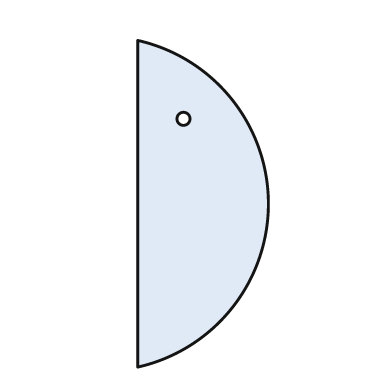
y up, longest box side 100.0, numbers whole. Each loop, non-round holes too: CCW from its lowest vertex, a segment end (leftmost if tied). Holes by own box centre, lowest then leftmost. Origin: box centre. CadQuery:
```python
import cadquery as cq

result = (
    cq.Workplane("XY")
    .moveTo(-20.0, -50.0)
    .threePointArc((20.0, 0.0), (-20.0, 50.0))
    .close()
    .moveTo(-6.0, 26.0)
    .circle(2.0)
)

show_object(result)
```